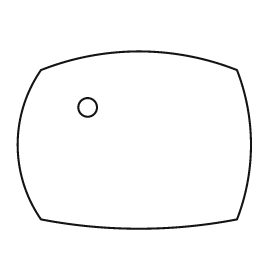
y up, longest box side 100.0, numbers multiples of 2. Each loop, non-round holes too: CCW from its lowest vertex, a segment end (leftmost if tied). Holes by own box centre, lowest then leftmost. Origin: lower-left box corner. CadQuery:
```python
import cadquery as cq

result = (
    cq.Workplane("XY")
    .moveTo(10.0, 4.0)
    .threePointArc((52.0, 0.0), (94.0, 4.0))
    .threePointArc((100.0, 36.0), (94.0, 68.0))
    .threePointArc((52.0, 76.0), (10.0, 68.0))
    .threePointArc((0.0, 36.0), (10.0, 4.0))
    .close()
    .moveTo(30.0, 52.0)
    .circle(4.0)
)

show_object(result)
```